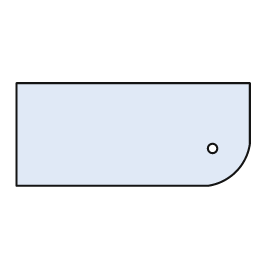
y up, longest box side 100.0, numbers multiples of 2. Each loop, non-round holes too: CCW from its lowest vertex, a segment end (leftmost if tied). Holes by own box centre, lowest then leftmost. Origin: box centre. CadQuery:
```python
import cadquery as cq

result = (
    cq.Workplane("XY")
    .moveTo(-50.0, -22.0)
    .lineTo(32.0, -22.0)
    .threePointArc((44.0, -16.0), (50.0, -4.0))
    .lineTo(50.0, 22.0)
    .lineTo(-50.0, 22.0)
    .close()
    .moveTo(34.0, -6.0)
    .circle(2.0)
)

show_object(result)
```